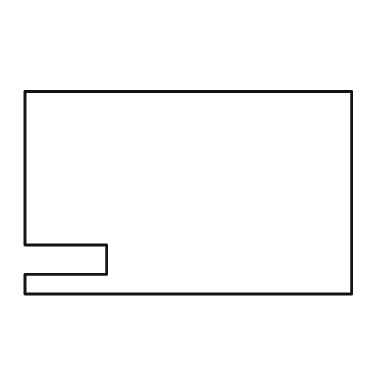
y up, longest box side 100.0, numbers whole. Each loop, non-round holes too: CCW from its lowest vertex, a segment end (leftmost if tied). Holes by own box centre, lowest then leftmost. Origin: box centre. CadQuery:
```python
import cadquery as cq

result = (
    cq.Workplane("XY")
    .moveTo(-50.0, -31.0)
    .lineTo(50.0, -31.0)
    .lineTo(50.0, 31.0)
    .lineTo(-50.0, 31.0)
    .lineTo(-50.0, -16.0)
    .lineTo(-25.0, -16.0)
    .lineTo(-25.0, -25.0)
    .lineTo(-50.0, -25.0)
    .close()
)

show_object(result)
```